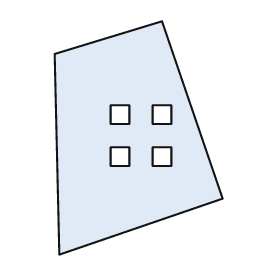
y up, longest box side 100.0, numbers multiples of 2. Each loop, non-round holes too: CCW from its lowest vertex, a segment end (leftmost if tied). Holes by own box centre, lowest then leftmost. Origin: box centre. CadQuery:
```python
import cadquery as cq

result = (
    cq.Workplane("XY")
    .moveTo(-34.0, -50.0)
    .lineTo(36.0, -26.0)
    .lineTo(10.0, 50.0)
    .lineTo(-36.0, 36.0)
    .close()
    .moveTo(-12.0, -12.0)
    .lineTo(-4.0, -12.0)
    .lineTo(-4.0, -4.0)
    .lineTo(-12.0, -4.0)
    .close()
    .moveTo(6.0, -12.0)
    .lineTo(14.0, -12.0)
    .lineTo(14.0, -4.0)
    .lineTo(6.0, -4.0)
    .close()
    .moveTo(-12.0, 6.0)
    .lineTo(-4.0, 6.0)
    .lineTo(-4.0, 14.0)
    .lineTo(-12.0, 14.0)
    .close()
    .moveTo(6.0, 6.0)
    .lineTo(14.0, 6.0)
    .lineTo(14.0, 14.0)
    .lineTo(6.0, 14.0)
    .close()
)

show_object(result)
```